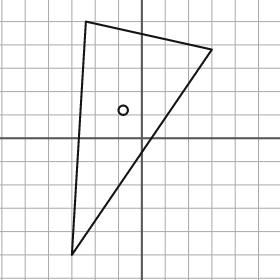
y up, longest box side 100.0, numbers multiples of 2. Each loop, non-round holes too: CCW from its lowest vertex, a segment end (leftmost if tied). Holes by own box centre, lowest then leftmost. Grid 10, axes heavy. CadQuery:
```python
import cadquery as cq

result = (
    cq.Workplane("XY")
    .moveTo(-30.0, -50.0)
    .lineTo(30.0, 38.0)
    .lineTo(-24.0, 50.0)
    .close()
    .moveTo(-8.0, 12.0)
    .circle(2.0)
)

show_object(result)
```